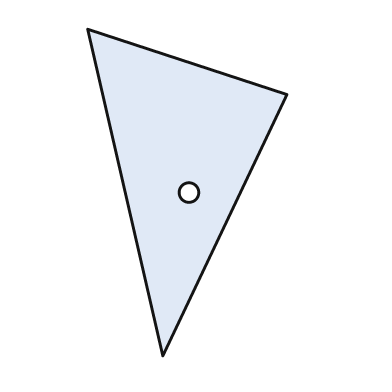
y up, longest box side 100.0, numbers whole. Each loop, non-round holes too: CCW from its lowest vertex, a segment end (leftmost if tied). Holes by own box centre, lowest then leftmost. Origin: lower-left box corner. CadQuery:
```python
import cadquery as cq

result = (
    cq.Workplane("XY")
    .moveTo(23.0, 0.0)
    .lineTo(61.0, 80.0)
    .lineTo(0.0, 100.0)
    .close()
    .moveTo(31.0, 50.0)
    .circle(3.0)
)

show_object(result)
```